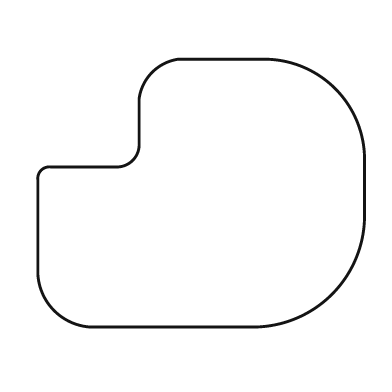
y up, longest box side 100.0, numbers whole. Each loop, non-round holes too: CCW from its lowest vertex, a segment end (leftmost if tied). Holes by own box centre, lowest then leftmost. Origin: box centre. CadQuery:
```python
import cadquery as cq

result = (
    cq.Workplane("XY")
    .moveTo(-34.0, -41.0)
    .lineTo(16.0, -41.0)
    .threePointArc((40.0, -31.0), (50.0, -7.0))
    .lineTo(50.0, 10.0)
    .threePointArc((41.0, 32.0), (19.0, 41.0))
    .lineTo(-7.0, 41.0)
    .threePointArc((-15.0, 37.0), (-19.0, 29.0))
    .lineTo(-19.0, 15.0)
    .threePointArc((-21.0, 10.0), (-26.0, 8.0))
    .lineTo(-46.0, 8.0)
    .threePointArc((-49.0, 7.0), (-50.0, 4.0))
    .lineTo(-50.0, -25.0)
    .threePointArc((-45.0, -36.0), (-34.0, -41.0))
    .close()
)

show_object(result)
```